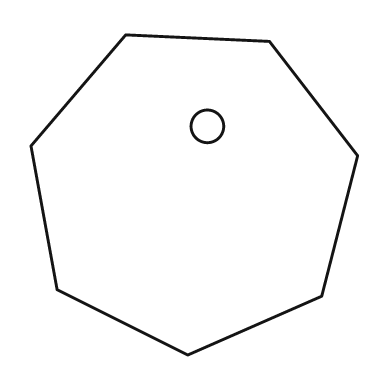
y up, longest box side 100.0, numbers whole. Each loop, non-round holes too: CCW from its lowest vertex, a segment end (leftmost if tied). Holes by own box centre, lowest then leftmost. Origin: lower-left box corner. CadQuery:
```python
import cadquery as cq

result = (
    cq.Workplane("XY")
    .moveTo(48.0, 0.0)
    .lineTo(89.0, 18.0)
    .lineTo(100.0, 61.0)
    .lineTo(73.0, 96.0)
    .lineTo(29.0, 98.0)
    .lineTo(0.0, 64.0)
    .lineTo(8.0, 20.0)
    .close()
    .moveTo(54.0, 70.0)
    .circle(5.0)
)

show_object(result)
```